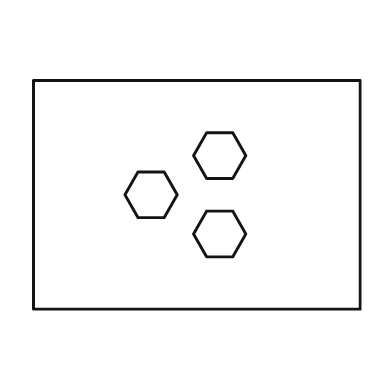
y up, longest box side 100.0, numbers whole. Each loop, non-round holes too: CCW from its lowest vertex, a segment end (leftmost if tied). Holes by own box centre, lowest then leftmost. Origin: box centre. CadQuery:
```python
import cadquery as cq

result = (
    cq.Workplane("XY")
    .moveTo(-50.0, -35.0)
    .lineTo(50.0, -35.0)
    .lineTo(50.0, 35.0)
    .lineTo(-50.0, 35.0)
    .close()
    .moveTo(3.0, -19.0)
    .lineTo(11.0, -19.0)
    .lineTo(15.0, -12.0)
    .lineTo(11.0, -5.0)
    .lineTo(3.0, -5.0)
    .lineTo(-1.0, -12.0)
    .close()
    .moveTo(-18.0, -7.0)
    .lineTo(-10.0, -7.0)
    .lineTo(-6.0, 0.0)
    .lineTo(-10.0, 7.0)
    .lineTo(-18.0, 7.0)
    .lineTo(-22.0, 0.0)
    .close()
    .moveTo(3.0, 5.0)
    .lineTo(11.0, 5.0)
    .lineTo(15.0, 12.0)
    .lineTo(11.0, 19.0)
    .lineTo(3.0, 19.0)
    .lineTo(-1.0, 12.0)
    .close()
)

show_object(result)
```